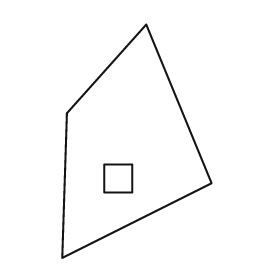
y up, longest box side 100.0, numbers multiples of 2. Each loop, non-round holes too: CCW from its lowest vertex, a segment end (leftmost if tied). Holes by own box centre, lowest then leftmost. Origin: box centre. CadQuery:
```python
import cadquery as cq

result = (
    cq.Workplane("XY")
    .moveTo(-32.0, -50.0)
    .lineTo(32.0, -18.0)
    .lineTo(4.0, 50.0)
    .lineTo(-30.0, 12.0)
    .close()
    .moveTo(-14.0, -22.0)
    .lineTo(-2.0, -22.0)
    .lineTo(-2.0, -10.0)
    .lineTo(-14.0, -10.0)
    .close()
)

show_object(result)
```